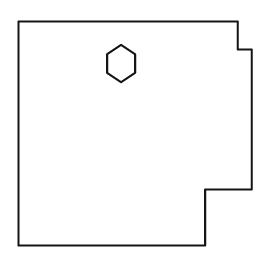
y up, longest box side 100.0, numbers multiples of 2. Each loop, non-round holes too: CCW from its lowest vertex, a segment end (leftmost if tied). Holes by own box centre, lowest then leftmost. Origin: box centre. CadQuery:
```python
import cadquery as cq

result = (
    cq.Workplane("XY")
    .moveTo(-50.0, -48.0)
    .lineTo(30.0, -48.0)
    .lineTo(30.0, -24.0)
    .lineTo(50.0, -24.0)
    .lineTo(50.0, 36.0)
    .lineTo(44.0, 36.0)
    .lineTo(44.0, 48.0)
    .lineTo(-50.0, 48.0)
    .close()
    .moveTo(-6.0, 22.0)
    .lineTo(0.0, 26.0)
    .lineTo(0.0, 34.0)
    .lineTo(-6.0, 38.0)
    .lineTo(-12.0, 34.0)
    .lineTo(-12.0, 26.0)
    .close()
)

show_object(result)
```